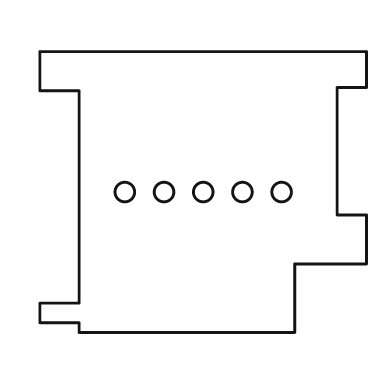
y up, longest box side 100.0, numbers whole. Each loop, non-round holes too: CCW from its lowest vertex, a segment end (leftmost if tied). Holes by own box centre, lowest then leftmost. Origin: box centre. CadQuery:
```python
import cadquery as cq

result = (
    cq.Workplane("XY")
    .moveTo(-38.0, -43.0)
    .lineTo(28.0, -43.0)
    .lineTo(28.0, -22.0)
    .lineTo(50.0, -22.0)
    .lineTo(50.0, -7.0)
    .lineTo(41.0, -7.0)
    .lineTo(41.0, 32.0)
    .lineTo(50.0, 32.0)
    .lineTo(50.0, 43.0)
    .lineTo(-50.0, 43.0)
    .lineTo(-50.0, 31.0)
    .lineTo(-38.0, 31.0)
    .lineTo(-38.0, -34.0)
    .lineTo(-50.0, -34.0)
    .lineTo(-50.0, -40.0)
    .lineTo(-38.0, -40.0)
    .close()
    .moveTo(-24.0, 0.0)
    .circle(3.0)
    .moveTo(-12.0, 0.0)
    .circle(3.0)
    .moveTo(0.0, 0.0)
    .circle(3.0)
    .moveTo(12.0, 0.0)
    .circle(3.0)
    .moveTo(24.0, 0.0)
    .circle(3.0)
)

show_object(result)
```